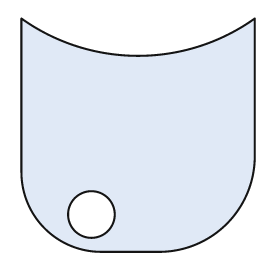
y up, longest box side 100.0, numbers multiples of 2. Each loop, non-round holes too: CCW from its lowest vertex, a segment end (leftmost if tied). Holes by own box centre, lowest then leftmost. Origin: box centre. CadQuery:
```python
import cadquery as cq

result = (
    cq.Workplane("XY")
    .moveTo(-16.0, -50.0)
    .lineTo(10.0, -50.0)
    .threePointArc((38.0, -38.0), (50.0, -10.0))
    .lineTo(50.0, 50.0)
    .threePointArc((0.0, 34.0), (-50.0, 50.0))
    .lineTo(-50.0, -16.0)
    .threePointArc((-40.0, -40.0), (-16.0, -50.0))
    .close()
    .moveTo(-20.0, -34.0)
    .circle(10.0)
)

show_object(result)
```